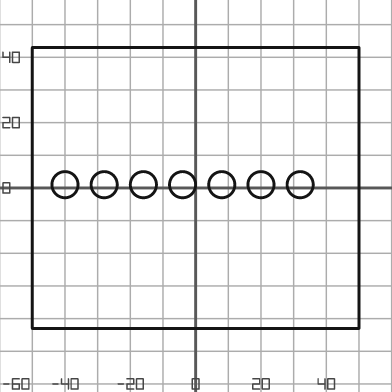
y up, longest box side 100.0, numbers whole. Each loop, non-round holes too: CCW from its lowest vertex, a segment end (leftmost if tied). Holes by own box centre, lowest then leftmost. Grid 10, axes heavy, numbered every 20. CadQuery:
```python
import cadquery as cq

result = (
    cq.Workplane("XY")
    .moveTo(-50.0, -43.0)
    .lineTo(50.0, -43.0)
    .lineTo(50.0, 43.0)
    .lineTo(-50.0, 43.0)
    .close()
    .moveTo(-40.0, 1.0)
    .circle(4.0)
    .moveTo(-28.0, 1.0)
    .circle(4.0)
    .moveTo(-16.0, 1.0)
    .circle(4.0)
    .moveTo(-4.0, 1.0)
    .circle(4.0)
    .moveTo(8.0, 1.0)
    .circle(4.0)
    .moveTo(20.0, 1.0)
    .circle(4.0)
    .moveTo(32.0, 1.0)
    .circle(4.0)
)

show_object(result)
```